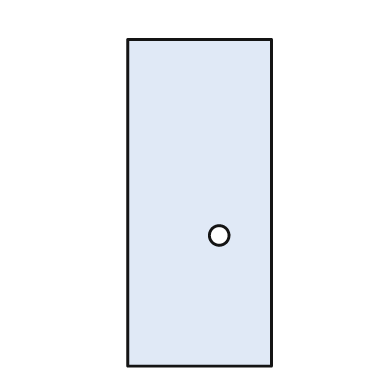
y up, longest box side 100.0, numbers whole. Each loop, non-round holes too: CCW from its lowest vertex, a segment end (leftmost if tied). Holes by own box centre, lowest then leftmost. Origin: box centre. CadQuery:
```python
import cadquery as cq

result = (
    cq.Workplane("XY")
    .moveTo(-22.0, -50.0)
    .lineTo(22.0, -50.0)
    .lineTo(22.0, 50.0)
    .lineTo(-22.0, 50.0)
    .close()
    .moveTo(6.0, -10.0)
    .circle(3.0)
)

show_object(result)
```